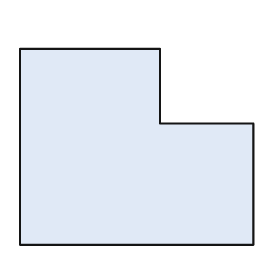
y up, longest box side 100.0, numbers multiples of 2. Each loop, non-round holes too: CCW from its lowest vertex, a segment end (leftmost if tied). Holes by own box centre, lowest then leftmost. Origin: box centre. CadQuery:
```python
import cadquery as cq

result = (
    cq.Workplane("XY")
    .moveTo(-50.0, -42.0)
    .lineTo(50.0, -42.0)
    .lineTo(50.0, 10.0)
    .lineTo(10.0, 10.0)
    .lineTo(10.0, 42.0)
    .lineTo(-50.0, 42.0)
    .close()
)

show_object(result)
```